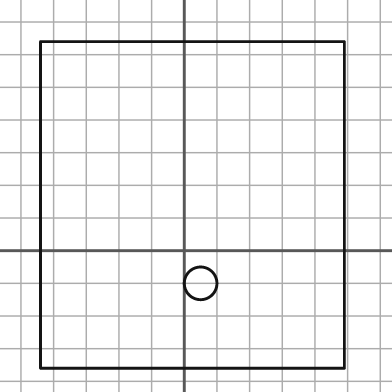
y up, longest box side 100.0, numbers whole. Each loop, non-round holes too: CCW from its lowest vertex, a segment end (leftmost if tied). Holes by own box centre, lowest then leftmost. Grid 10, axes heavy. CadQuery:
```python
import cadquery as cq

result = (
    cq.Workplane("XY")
    .moveTo(-44.0, -36.0)
    .lineTo(49.0, -36.0)
    .lineTo(49.0, 64.0)
    .lineTo(-44.0, 64.0)
    .close()
    .moveTo(5.0, -10.0)
    .circle(5.0)
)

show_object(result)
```